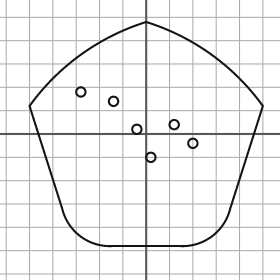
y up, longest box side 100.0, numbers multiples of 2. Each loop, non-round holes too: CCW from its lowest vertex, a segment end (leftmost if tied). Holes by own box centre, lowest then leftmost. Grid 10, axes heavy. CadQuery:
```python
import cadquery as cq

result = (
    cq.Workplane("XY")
    .moveTo(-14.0, -48.0)
    .lineTo(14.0, -48.0)
    .threePointArc((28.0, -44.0), (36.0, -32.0))
    .lineTo(50.0, 12.0)
    .threePointArc((28.0, 34.0), (0.0, 48.0))
    .threePointArc((-28.0, 34.0), (-50.0, 12.0))
    .lineTo(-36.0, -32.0)
    .threePointArc((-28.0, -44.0), (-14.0, -48.0))
    .close()
    .moveTo(2.0, -10.0)
    .circle(2.0)
    .moveTo(20.0, -4.0)
    .circle(2.0)
    .moveTo(-4.0, 2.0)
    .circle(2.0)
    .moveTo(12.0, 4.0)
    .circle(2.0)
    .moveTo(-14.0, 14.0)
    .circle(2.0)
    .moveTo(-28.0, 18.0)
    .circle(2.0)
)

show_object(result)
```